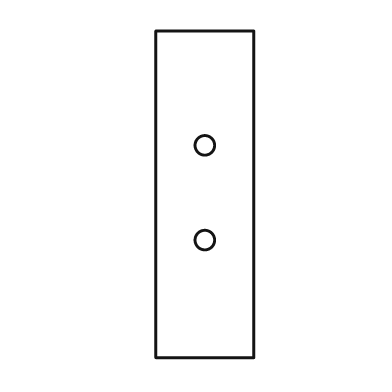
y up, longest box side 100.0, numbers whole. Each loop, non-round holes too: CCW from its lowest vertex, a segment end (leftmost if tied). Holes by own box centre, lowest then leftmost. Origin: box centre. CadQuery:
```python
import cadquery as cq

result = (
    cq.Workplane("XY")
    .moveTo(-15.0, -50.0)
    .lineTo(15.0, -50.0)
    .lineTo(15.0, 50.0)
    .lineTo(-15.0, 50.0)
    .close()
    .moveTo(0.0, -14.0)
    .circle(3.0)
    .moveTo(0.0, 15.0)
    .circle(3.0)
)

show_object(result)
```